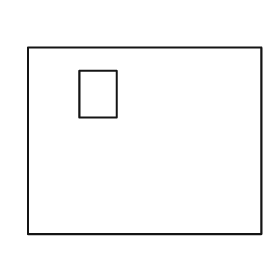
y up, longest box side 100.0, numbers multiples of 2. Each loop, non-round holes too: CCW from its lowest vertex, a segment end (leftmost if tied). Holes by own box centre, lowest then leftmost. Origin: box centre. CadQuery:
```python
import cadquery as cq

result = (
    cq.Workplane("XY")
    .moveTo(-50.0, -40.0)
    .lineTo(50.0, -40.0)
    .lineTo(50.0, 40.0)
    .lineTo(-50.0, 40.0)
    .close()
    .moveTo(-28.0, 10.0)
    .lineTo(-12.0, 10.0)
    .lineTo(-12.0, 30.0)
    .lineTo(-28.0, 30.0)
    .close()
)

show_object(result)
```